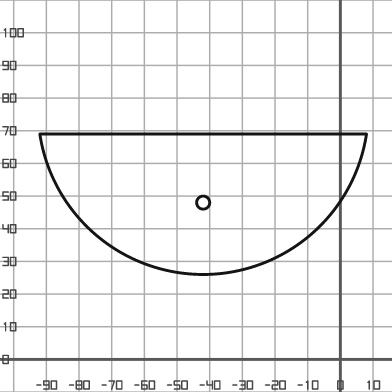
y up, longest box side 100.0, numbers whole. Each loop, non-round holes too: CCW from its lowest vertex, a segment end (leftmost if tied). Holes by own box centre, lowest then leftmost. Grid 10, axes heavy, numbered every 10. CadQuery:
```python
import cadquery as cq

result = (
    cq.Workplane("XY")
    .moveTo(-92.0, 69.0)
    .threePointArc((-42.0, 26.0), (8.0, 69.0))
    .close()
    .moveTo(-42.0, 48.0)
    .circle(2.0)
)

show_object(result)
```